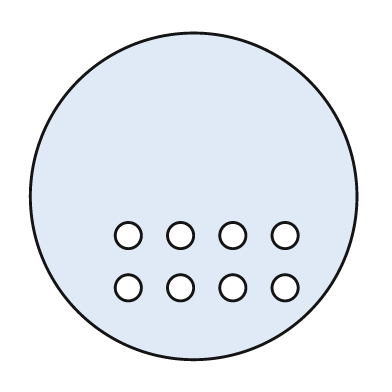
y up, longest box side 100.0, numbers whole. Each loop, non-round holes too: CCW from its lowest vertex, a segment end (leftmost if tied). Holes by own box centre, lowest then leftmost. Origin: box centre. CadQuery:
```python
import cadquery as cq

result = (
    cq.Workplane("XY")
    .moveTo(0.0, 0.0)
    .circle(50.0)
    .moveTo(-20.0, -28.0)
    .circle(4.0)
    .moveTo(-4.0, -28.0)
    .circle(4.0)
    .moveTo(12.0, -28.0)
    .circle(4.0)
    .moveTo(28.0, -28.0)
    .circle(4.0)
    .moveTo(-20.0, -12.0)
    .circle(4.0)
    .moveTo(-4.0, -12.0)
    .circle(4.0)
    .moveTo(12.0, -12.0)
    .circle(4.0)
    .moveTo(28.0, -12.0)
    .circle(4.0)
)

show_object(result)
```